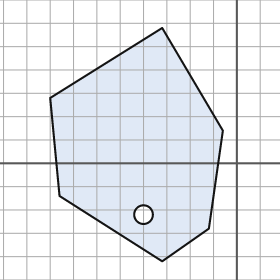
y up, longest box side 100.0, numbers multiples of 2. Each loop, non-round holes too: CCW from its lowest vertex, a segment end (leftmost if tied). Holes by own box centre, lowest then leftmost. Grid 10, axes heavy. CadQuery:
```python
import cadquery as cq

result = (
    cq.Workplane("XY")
    .moveTo(-32.0, -42.0)
    .lineTo(-12.0, -28.0)
    .lineTo(-6.0, 14.0)
    .lineTo(-32.0, 58.0)
    .lineTo(-80.0, 28.0)
    .lineTo(-76.0, -14.0)
    .close()
    .moveTo(-40.0, -22.0)
    .circle(4.0)
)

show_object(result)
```